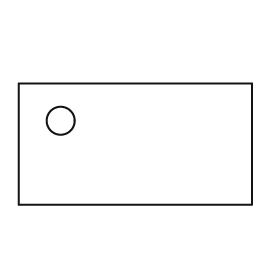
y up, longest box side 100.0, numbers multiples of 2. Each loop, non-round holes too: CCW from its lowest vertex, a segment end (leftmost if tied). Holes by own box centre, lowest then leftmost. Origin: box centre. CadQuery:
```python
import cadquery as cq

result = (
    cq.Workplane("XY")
    .moveTo(-50.0, -26.0)
    .lineTo(50.0, -26.0)
    .lineTo(50.0, 26.0)
    .lineTo(-50.0, 26.0)
    .close()
    .moveTo(-32.0, 10.0)
    .circle(6.0)
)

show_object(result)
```